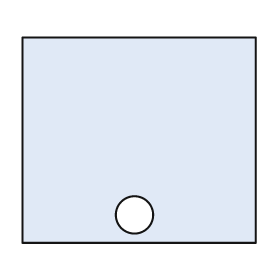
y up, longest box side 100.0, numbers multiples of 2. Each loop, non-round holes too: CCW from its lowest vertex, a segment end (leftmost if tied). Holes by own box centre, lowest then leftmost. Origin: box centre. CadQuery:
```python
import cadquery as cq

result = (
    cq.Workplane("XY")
    .moveTo(-50.0, -44.0)
    .lineTo(50.0, -44.0)
    .lineTo(50.0, 44.0)
    .lineTo(-50.0, 44.0)
    .close()
    .moveTo(-2.0, -32.0)
    .circle(8.0)
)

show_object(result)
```